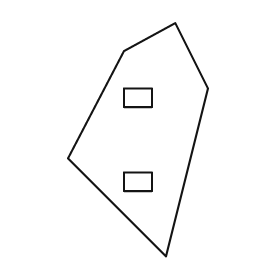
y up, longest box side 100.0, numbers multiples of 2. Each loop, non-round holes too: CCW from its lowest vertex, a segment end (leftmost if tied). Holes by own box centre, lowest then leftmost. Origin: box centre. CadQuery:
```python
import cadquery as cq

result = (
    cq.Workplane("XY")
    .moveTo(12.0, -50.0)
    .lineTo(30.0, 22.0)
    .lineTo(16.0, 50.0)
    .lineTo(-6.0, 38.0)
    .lineTo(-30.0, -8.0)
    .close()
    .moveTo(-6.0, -22.0)
    .lineTo(6.0, -22.0)
    .lineTo(6.0, -14.0)
    .lineTo(-6.0, -14.0)
    .close()
    .moveTo(-6.0, 14.0)
    .lineTo(6.0, 14.0)
    .lineTo(6.0, 22.0)
    .lineTo(-6.0, 22.0)
    .close()
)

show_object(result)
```